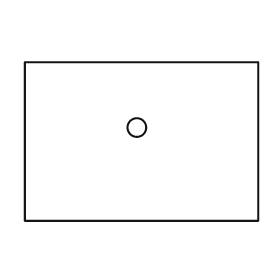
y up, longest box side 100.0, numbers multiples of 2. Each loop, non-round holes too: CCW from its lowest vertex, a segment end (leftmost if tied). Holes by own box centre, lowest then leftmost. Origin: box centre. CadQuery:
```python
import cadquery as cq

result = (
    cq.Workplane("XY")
    .moveTo(-50.0, -34.0)
    .lineTo(50.0, -34.0)
    .lineTo(50.0, 34.0)
    .lineTo(-50.0, 34.0)
    .close()
    .moveTo(-2.0, 6.0)
    .circle(4.0)
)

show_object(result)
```